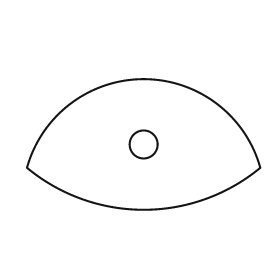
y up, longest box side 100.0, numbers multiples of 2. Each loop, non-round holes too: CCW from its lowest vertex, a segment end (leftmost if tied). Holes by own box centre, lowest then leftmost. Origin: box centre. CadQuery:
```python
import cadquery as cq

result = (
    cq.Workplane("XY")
    .moveTo(-50.0, -10.0)
    .threePointArc((0.0, -28.0), (50.0, -10.0))
    .threePointArc((0.0, 28.0), (-50.0, -10.0))
    .close()
    .moveTo(0.0, 0.0)
    .circle(6.0)
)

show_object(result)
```